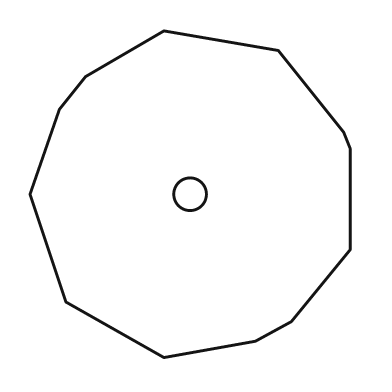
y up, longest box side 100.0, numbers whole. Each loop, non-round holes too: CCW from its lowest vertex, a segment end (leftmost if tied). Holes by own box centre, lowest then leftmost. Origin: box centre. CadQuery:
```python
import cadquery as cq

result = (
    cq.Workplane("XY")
    .moveTo(-8.0, -50.0)
    .lineTo(20.0, -45.0)
    .lineTo(31.0, -39.0)
    .lineTo(49.0, -17.0)
    .lineTo(49.0, 14.0)
    .lineTo(47.0, 19.0)
    .lineTo(27.0, 44.0)
    .lineTo(-8.0, 50.0)
    .lineTo(-32.0, 36.0)
    .lineTo(-40.0, 26.0)
    .lineTo(-49.0, 0.0)
    .lineTo(-38.0, -33.0)
    .close()
    .moveTo(0.0, 0.0)
    .circle(5.0)
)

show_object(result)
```